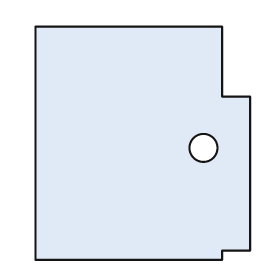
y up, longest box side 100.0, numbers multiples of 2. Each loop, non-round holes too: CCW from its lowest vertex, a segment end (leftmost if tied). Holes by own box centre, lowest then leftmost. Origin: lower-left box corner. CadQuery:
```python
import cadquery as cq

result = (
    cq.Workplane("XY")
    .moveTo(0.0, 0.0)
    .lineTo(80.0, 0.0)
    .lineTo(80.0, 4.0)
    .lineTo(92.0, 4.0)
    .lineTo(92.0, 70.0)
    .lineTo(80.0, 70.0)
    .lineTo(80.0, 100.0)
    .lineTo(0.0, 100.0)
    .close()
    .moveTo(72.0, 48.0)
    .circle(6.0)
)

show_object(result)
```